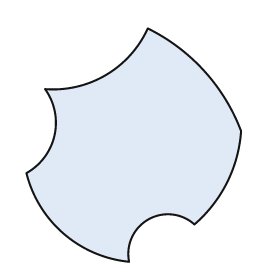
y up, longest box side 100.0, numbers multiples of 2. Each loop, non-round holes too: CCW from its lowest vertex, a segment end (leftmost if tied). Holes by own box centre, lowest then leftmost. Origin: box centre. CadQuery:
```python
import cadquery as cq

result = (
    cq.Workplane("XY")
    .moveTo(-2.0, -50.0)
    .threePointArc((6.0, -32.0), (26.0, -34.0))
    .threePointArc((40.0, -16.0), (46.0, 6.0))
    .threePointArc((30.0, 32.0), (6.0, 50.0))
    .threePointArc((-12.0, 30.0), (-38.0, 24.0))
    .threePointArc((-34.0, 4.0), (-46.0, -12.0))
    .threePointArc((-30.0, -38.0), (-2.0, -50.0))
    .close()
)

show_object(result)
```